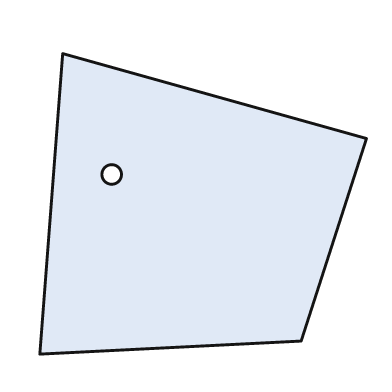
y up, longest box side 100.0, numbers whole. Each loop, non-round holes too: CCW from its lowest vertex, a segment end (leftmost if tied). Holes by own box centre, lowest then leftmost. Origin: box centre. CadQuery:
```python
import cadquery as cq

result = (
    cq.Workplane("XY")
    .moveTo(-50.0, -46.0)
    .lineTo(30.0, -42.0)
    .lineTo(50.0, 20.0)
    .lineTo(-43.0, 46.0)
    .close()
    .moveTo(-28.0, 9.0)
    .circle(3.0)
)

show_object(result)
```